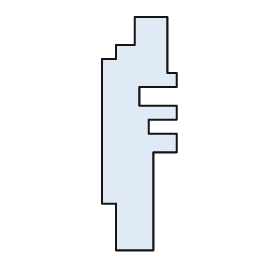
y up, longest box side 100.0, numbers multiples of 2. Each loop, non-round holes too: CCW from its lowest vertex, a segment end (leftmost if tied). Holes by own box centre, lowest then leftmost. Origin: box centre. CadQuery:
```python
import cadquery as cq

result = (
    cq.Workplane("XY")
    .moveTo(-10.0, -50.0)
    .lineTo(6.0, -50.0)
    .lineTo(6.0, -8.0)
    .lineTo(16.0, -8.0)
    .lineTo(16.0, 0.0)
    .lineTo(4.0, 0.0)
    .lineTo(4.0, 6.0)
    .lineTo(16.0, 6.0)
    .lineTo(16.0, 12.0)
    .lineTo(0.0, 12.0)
    .lineTo(0.0, 20.0)
    .lineTo(16.0, 20.0)
    .lineTo(16.0, 26.0)
    .lineTo(12.0, 26.0)
    .lineTo(12.0, 50.0)
    .lineTo(-2.0, 50.0)
    .lineTo(-2.0, 38.0)
    .lineTo(-10.0, 38.0)
    .lineTo(-10.0, 32.0)
    .lineTo(-16.0, 32.0)
    .lineTo(-16.0, -30.0)
    .lineTo(-10.0, -30.0)
    .close()
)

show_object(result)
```